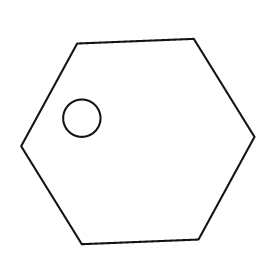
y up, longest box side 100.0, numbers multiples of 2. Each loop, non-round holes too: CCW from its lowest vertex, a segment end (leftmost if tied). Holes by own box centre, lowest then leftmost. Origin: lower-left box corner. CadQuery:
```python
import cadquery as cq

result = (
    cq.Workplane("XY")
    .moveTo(26.0, 0.0)
    .lineTo(76.0, 2.0)
    .lineTo(100.0, 46.0)
    .lineTo(74.0, 88.0)
    .lineTo(24.0, 86.0)
    .lineTo(0.0, 42.0)
    .close()
    .moveTo(26.0, 54.0)
    .circle(8.0)
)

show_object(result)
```